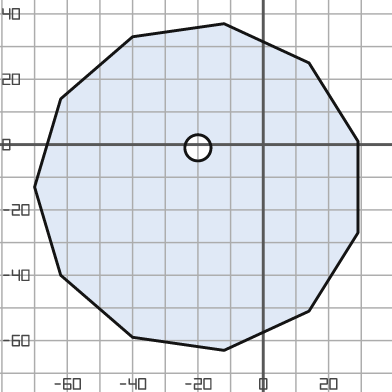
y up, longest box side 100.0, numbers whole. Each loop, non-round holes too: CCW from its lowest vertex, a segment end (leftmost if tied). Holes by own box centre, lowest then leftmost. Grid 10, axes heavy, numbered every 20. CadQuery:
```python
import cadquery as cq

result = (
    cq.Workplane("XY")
    .moveTo(-12.0, -63.0)
    .lineTo(14.0, -51.0)
    .lineTo(29.0, -27.0)
    .lineTo(29.0, 1.0)
    .lineTo(14.0, 25.0)
    .lineTo(-12.0, 37.0)
    .lineTo(-40.0, 33.0)
    .lineTo(-62.0, 14.0)
    .lineTo(-70.0, -13.0)
    .lineTo(-62.0, -40.0)
    .lineTo(-40.0, -59.0)
    .close()
    .moveTo(-20.0, -1.0)
    .circle(4.0)
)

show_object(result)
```